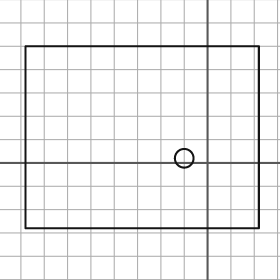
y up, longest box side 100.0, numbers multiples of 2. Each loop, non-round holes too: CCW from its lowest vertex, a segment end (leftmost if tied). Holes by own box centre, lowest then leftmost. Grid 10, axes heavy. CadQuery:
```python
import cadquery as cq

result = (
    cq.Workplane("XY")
    .moveTo(-78.0, -28.0)
    .lineTo(22.0, -28.0)
    .lineTo(22.0, 50.0)
    .lineTo(-78.0, 50.0)
    .close()
    .moveTo(-10.0, 2.0)
    .circle(4.0)
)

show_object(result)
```